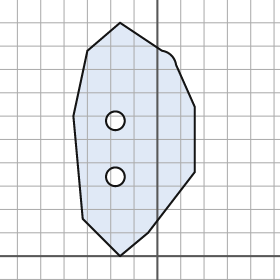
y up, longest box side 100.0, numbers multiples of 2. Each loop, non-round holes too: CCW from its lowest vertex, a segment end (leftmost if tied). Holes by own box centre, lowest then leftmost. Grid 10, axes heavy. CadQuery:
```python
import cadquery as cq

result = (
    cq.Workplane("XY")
    .moveTo(-16.0, 0.0)
    .lineTo(-4.0, 10.0)
    .lineTo(16.0, 36.0)
    .lineTo(16.0, 64.0)
    .lineTo(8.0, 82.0)
    .threePointArc((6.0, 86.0), (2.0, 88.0))
    .lineTo(-16.0, 100.0)
    .lineTo(-30.0, 88.0)
    .lineTo(-36.0, 60.0)
    .lineTo(-32.0, 16.0)
    .close()
    .moveTo(-18.0, 34.0)
    .circle(4.0)
    .moveTo(-18.0, 58.0)
    .circle(4.0)
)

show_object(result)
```